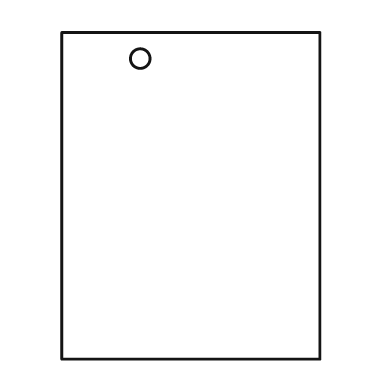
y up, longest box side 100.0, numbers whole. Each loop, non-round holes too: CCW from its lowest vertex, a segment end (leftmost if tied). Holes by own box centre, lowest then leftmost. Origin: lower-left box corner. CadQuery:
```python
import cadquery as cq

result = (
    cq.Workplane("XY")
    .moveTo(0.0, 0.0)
    .lineTo(79.0, 0.0)
    .lineTo(79.0, 100.0)
    .lineTo(0.0, 100.0)
    .close()
    .moveTo(24.0, 92.0)
    .circle(3.0)
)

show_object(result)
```